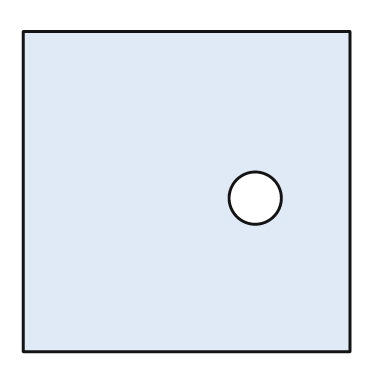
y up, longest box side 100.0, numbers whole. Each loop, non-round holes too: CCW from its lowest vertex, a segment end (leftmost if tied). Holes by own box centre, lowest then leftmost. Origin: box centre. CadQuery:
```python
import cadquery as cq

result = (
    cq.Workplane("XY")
    .moveTo(-50.0, -49.0)
    .lineTo(50.0, -49.0)
    .lineTo(50.0, 49.0)
    .lineTo(-50.0, 49.0)
    .close()
    .moveTo(21.0, -2.0)
    .circle(8.0)
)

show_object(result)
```